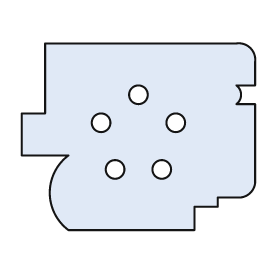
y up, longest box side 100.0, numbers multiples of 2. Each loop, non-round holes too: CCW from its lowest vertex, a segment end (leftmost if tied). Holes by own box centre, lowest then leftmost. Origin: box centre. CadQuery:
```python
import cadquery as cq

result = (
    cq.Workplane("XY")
    .moveTo(-30.0, -40.0)
    .lineTo(24.0, -40.0)
    .lineTo(24.0, -30.0)
    .lineTo(34.0, -30.0)
    .lineTo(34.0, -26.0)
    .lineTo(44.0, -26.0)
    .threePointArc((48.0, -24.0), (50.0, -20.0))
    .lineTo(50.0, 14.0)
    .lineTo(42.0, 14.0)
    .threePointArc((44.0, 18.0), (42.0, 22.0))
    .lineTo(50.0, 22.0)
    .lineTo(50.0, 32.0)
    .threePointArc((48.0, 38.0), (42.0, 40.0))
    .lineTo(-40.0, 40.0)
    .lineTo(-40.0, 10.0)
    .lineTo(-50.0, 10.0)
    .lineTo(-50.0, -8.0)
    .lineTo(-30.0, -8.0)
    .threePointArc((-38.0, -24.0), (-30.0, -40.0))
    .close()
    .moveTo(-10.0, -14.0)
    .circle(4.0)
    .moveTo(10.0, -14.0)
    .circle(4.0)
    .moveTo(-16.0, 6.0)
    .circle(4.0)
    .moveTo(16.0, 6.0)
    .circle(4.0)
    .moveTo(0.0, 18.0)
    .circle(4.0)
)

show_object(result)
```